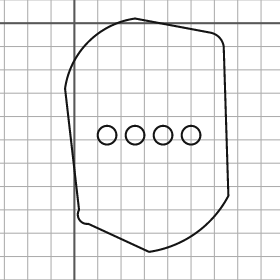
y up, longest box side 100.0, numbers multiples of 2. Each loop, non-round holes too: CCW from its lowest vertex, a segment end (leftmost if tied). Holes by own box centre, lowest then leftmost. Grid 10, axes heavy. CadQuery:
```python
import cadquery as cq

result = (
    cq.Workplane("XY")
    .moveTo(32.0, -98.0)
    .threePointArc((52.0, -90.0), (66.0, -74.0))
    .lineTo(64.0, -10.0)
    .threePointArc((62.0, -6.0), (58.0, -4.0))
    .lineTo(26.0, 2.0)
    .threePointArc((6.0, -8.0), (-4.0, -28.0))
    .lineTo(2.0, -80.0)
    .threePointArc((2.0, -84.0), (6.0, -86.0))
    .close()
    .moveTo(14.0, -48.0)
    .circle(4.0)
    .moveTo(26.0, -48.0)
    .circle(4.0)
    .moveTo(38.0, -48.0)
    .circle(4.0)
    .moveTo(50.0, -48.0)
    .circle(4.0)
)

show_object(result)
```